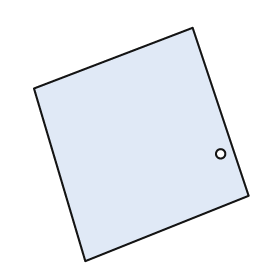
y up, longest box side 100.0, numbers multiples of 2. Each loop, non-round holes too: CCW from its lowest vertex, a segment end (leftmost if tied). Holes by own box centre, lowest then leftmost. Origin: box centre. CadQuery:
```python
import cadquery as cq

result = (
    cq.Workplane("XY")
    .moveTo(-24.0, -50.0)
    .lineTo(46.0, -22.0)
    .lineTo(22.0, 50.0)
    .lineTo(-46.0, 24.0)
    .close()
    .moveTo(34.0, -4.0)
    .circle(2.0)
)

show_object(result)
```